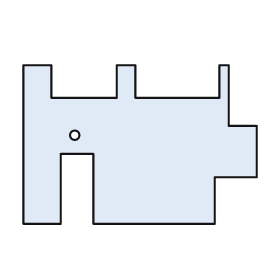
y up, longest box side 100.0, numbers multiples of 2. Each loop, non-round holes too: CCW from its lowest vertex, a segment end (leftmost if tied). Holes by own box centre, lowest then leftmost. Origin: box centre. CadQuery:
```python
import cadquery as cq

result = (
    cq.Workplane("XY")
    .moveTo(-50.0, -34.0)
    .lineTo(-34.0, -34.0)
    .lineTo(-34.0, -4.0)
    .lineTo(-20.0, -4.0)
    .lineTo(-20.0, -34.0)
    .lineTo(32.0, -34.0)
    .lineTo(32.0, -14.0)
    .lineTo(50.0, -14.0)
    .lineTo(50.0, 8.0)
    .lineTo(38.0, 8.0)
    .lineTo(38.0, 34.0)
    .lineTo(34.0, 34.0)
    .lineTo(34.0, 20.0)
    .lineTo(-2.0, 20.0)
    .lineTo(-2.0, 34.0)
    .lineTo(-10.0, 34.0)
    .lineTo(-10.0, 20.0)
    .lineTo(-38.0, 20.0)
    .lineTo(-38.0, 34.0)
    .lineTo(-50.0, 34.0)
    .close()
    .moveTo(-28.0, 4.0)
    .circle(2.0)
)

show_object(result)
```